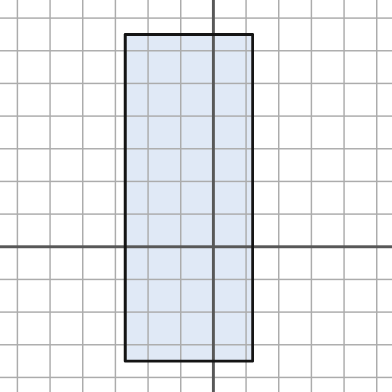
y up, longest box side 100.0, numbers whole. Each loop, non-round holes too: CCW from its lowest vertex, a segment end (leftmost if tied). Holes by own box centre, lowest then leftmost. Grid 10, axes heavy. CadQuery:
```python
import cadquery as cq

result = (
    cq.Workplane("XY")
    .moveTo(-27.0, -35.0)
    .lineTo(12.0, -35.0)
    .lineTo(12.0, 65.0)
    .lineTo(-27.0, 65.0)
    .close()
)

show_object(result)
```